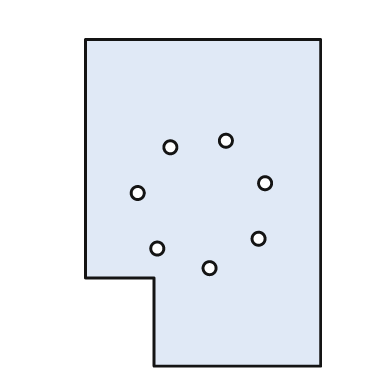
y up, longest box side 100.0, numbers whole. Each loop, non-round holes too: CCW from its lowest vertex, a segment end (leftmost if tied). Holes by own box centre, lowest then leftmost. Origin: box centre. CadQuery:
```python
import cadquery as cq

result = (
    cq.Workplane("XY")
    .moveTo(-15.0, -50.0)
    .lineTo(36.0, -50.0)
    .lineTo(36.0, 50.0)
    .lineTo(-36.0, 50.0)
    .lineTo(-36.0, -23.0)
    .lineTo(-15.0, -23.0)
    .close()
    .moveTo(2.0, -20.0)
    .circle(2.0)
    .moveTo(-14.0, -14.0)
    .circle(2.0)
    .moveTo(17.0, -11.0)
    .circle(2.0)
    .moveTo(-20.0, 3.0)
    .circle(2.0)
    .moveTo(19.0, 6.0)
    .circle(2.0)
    .moveTo(-10.0, 17.0)
    .circle(2.0)
    .moveTo(7.0, 19.0)
    .circle(2.0)
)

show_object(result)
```